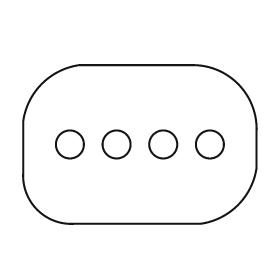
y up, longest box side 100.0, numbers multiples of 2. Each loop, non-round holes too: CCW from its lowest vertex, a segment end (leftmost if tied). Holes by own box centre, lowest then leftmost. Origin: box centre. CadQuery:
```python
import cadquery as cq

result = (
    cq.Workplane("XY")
    .moveTo(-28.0, -34.0)
    .lineTo(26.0, -34.0)
    .threePointArc((42.0, -26.0), (50.0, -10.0))
    .lineTo(50.0, 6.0)
    .threePointArc((42.0, 26.0), (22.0, 34.0))
    .lineTo(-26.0, 34.0)
    .threePointArc((-42.0, 26.0), (-50.0, 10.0))
    .lineTo(-50.0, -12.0)
    .threePointArc((-44.0, -28.0), (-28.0, -34.0))
    .close()
    .moveTo(-30.0, 0.0)
    .circle(6.0)
    .moveTo(-10.0, 0.0)
    .circle(6.0)
    .moveTo(10.0, 0.0)
    .circle(6.0)
    .moveTo(30.0, 0.0)
    .circle(6.0)
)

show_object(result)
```